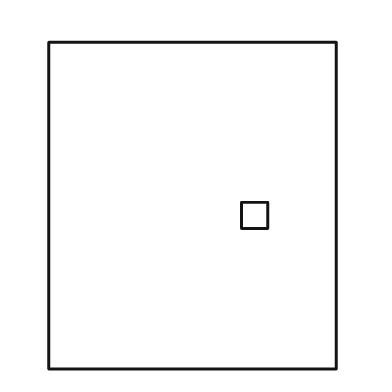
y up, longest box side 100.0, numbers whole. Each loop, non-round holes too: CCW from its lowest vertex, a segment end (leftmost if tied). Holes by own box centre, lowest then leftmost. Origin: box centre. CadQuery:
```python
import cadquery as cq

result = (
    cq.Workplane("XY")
    .moveTo(-44.0, -50.0)
    .lineTo(44.0, -50.0)
    .lineTo(44.0, 50.0)
    .lineTo(-44.0, 50.0)
    .close()
    .moveTo(15.0, -7.0)
    .lineTo(23.0, -7.0)
    .lineTo(23.0, 1.0)
    .lineTo(15.0, 1.0)
    .close()
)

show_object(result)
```